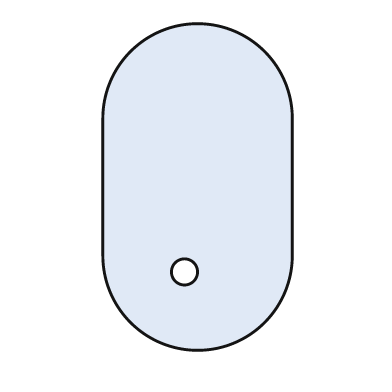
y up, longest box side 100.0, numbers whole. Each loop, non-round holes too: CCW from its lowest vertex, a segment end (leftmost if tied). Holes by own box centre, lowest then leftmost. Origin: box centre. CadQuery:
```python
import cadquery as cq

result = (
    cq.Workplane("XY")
    .moveTo(-29.0, -21.0)
    .threePointArc((0.0, -50.0), (29.0, -21.0))
    .lineTo(29.0, 21.0)
    .threePointArc((0.0, 50.0), (-29.0, 21.0))
    .close()
    .moveTo(-4.0, -26.0)
    .circle(4.0)
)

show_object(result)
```